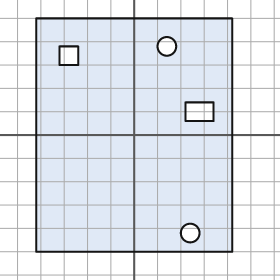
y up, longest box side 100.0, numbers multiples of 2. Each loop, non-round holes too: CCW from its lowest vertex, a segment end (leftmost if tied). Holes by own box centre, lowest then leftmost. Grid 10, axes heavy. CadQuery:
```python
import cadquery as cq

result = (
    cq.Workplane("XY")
    .moveTo(-42.0, -50.0)
    .lineTo(42.0, -50.0)
    .lineTo(42.0, 50.0)
    .lineTo(-42.0, 50.0)
    .close()
    .moveTo(24.0, -42.0)
    .circle(4.0)
    .moveTo(22.0, 6.0)
    .lineTo(34.0, 6.0)
    .lineTo(34.0, 14.0)
    .lineTo(22.0, 14.0)
    .close()
    .moveTo(-32.0, 30.0)
    .lineTo(-24.0, 30.0)
    .lineTo(-24.0, 38.0)
    .lineTo(-32.0, 38.0)
    .close()
    .moveTo(14.0, 38.0)
    .circle(4.0)
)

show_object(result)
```